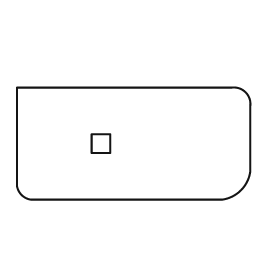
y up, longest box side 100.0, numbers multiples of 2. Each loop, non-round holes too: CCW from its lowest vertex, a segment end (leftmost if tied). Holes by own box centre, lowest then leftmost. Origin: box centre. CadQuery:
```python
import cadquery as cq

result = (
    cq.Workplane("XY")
    .moveTo(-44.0, -24.0)
    .lineTo(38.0, -24.0)
    .threePointArc((46.0, -20.0), (50.0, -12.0))
    .lineTo(50.0, 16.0)
    .threePointArc((48.0, 22.0), (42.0, 24.0))
    .lineTo(-50.0, 24.0)
    .lineTo(-50.0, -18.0)
    .threePointArc((-48.0, -22.0), (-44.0, -24.0))
    .close()
    .moveTo(-18.0, -4.0)
    .lineTo(-10.0, -4.0)
    .lineTo(-10.0, 4.0)
    .lineTo(-18.0, 4.0)
    .close()
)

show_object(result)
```